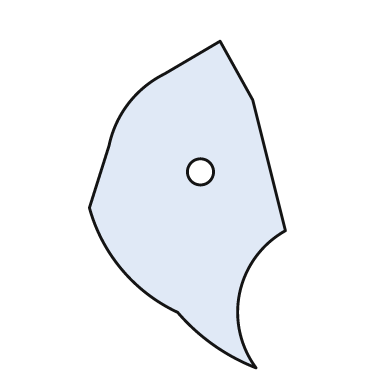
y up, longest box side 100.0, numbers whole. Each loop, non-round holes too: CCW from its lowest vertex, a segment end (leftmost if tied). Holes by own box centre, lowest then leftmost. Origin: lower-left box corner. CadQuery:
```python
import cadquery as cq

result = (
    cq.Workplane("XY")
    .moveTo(51.0, 0.0)
    .threePointArc((46.0, 23.0), (60.0, 42.0))
    .lineTo(50.0, 82.0)
    .lineTo(40.0, 100.0)
    .lineTo(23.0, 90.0)
    .threePointArc((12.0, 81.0), (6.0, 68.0))
    .lineTo(0.0, 49.0)
    .threePointArc((10.0, 30.0), (27.0, 17.0))
    .threePointArc((38.0, 7.0), (51.0, 0.0))
    .close()
    .moveTo(34.0, 60.0)
    .circle(4.0)
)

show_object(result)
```